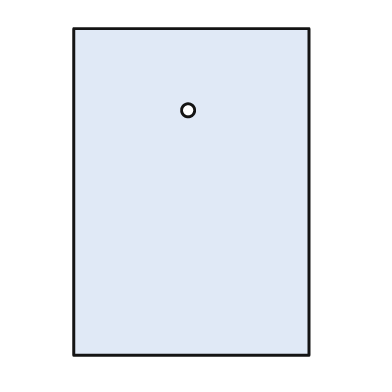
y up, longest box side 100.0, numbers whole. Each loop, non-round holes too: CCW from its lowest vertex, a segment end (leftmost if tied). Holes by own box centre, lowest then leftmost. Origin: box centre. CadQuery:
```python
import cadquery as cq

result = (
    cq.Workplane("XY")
    .moveTo(-36.0, -50.0)
    .lineTo(36.0, -50.0)
    .lineTo(36.0, 50.0)
    .lineTo(-36.0, 50.0)
    .close()
    .moveTo(-1.0, 25.0)
    .circle(2.0)
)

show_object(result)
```